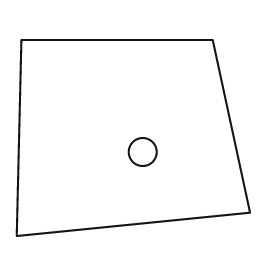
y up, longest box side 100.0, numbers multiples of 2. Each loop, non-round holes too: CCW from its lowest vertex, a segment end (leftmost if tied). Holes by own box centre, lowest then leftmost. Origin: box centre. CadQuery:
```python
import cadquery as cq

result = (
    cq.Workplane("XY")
    .moveTo(-50.0, -42.0)
    .lineTo(50.0, -32.0)
    .lineTo(34.0, 42.0)
    .lineTo(-48.0, 42.0)
    .close()
    .moveTo(4.0, -6.0)
    .circle(6.0)
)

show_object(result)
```